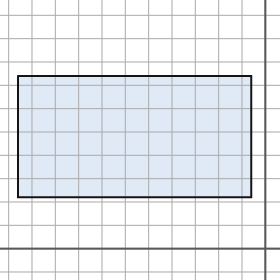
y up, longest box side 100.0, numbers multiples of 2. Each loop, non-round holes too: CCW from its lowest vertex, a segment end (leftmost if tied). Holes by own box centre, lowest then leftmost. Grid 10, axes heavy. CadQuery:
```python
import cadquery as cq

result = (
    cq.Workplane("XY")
    .moveTo(-106.0, 22.0)
    .lineTo(-6.0, 22.0)
    .lineTo(-6.0, 74.0)
    .lineTo(-106.0, 74.0)
    .close()
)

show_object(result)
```